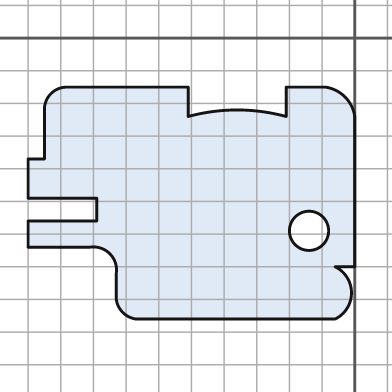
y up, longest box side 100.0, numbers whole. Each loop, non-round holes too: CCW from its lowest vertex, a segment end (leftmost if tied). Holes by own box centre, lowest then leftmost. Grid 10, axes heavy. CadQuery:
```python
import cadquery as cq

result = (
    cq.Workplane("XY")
    .moveTo(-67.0, -86.0)
    .lineTo(-6.0, -86.0)
    .threePointArc((-1.0, -78.0), (-6.0, -70.0))
    .lineTo(0.0, -70.0)
    .lineTo(0.0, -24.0)
    .threePointArc((-3.0, -18.0), (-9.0, -15.0))
    .lineTo(-21.0, -15.0)
    .lineTo(-21.0, -24.0)
    .threePointArc((-36.0, -22.0), (-51.0, -24.0))
    .lineTo(-51.0, -15.0)
    .lineTo(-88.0, -15.0)
    .threePointArc((-93.0, -17.0), (-95.0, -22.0))
    .lineTo(-95.0, -37.0)
    .lineTo(-100.0, -37.0)
    .lineTo(-100.0, -49.0)
    .lineTo(-79.0, -49.0)
    .lineTo(-79.0, -56.0)
    .lineTo(-100.0, -56.0)
    .lineTo(-100.0, -64.0)
    .lineTo(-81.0, -64.0)
    .threePointArc((-75.0, -66.0), (-73.0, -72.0))
    .lineTo(-73.0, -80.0)
    .threePointArc((-71.0, -84.0), (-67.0, -86.0))
    .close()
    .moveTo(-14.0, -59.0)
    .circle(6.0)
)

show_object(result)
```